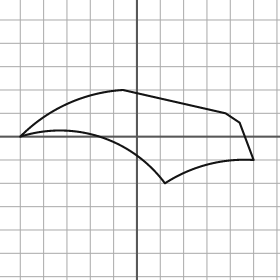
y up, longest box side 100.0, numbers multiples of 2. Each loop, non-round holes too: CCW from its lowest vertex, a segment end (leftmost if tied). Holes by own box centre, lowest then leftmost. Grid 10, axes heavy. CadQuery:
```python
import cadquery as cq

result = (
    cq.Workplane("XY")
    .moveTo(12.0, -20.0)
    .threePointArc((30.0, -12.0), (50.0, -10.0))
    .lineTo(44.0, 6.0)
    .lineTo(38.0, 10.0)
    .lineTo(-6.0, 20.0)
    .threePointArc((-30.0, 14.0), (-50.0, 0.0))
    .threePointArc((-16.0, 0.0), (12.0, -20.0))
    .close()
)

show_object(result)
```